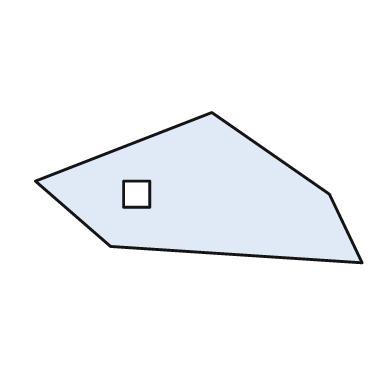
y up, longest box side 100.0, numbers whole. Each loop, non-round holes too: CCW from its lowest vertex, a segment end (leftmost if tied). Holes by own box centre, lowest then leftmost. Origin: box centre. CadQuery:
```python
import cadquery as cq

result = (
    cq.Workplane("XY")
    .moveTo(50.0, -23.0)
    .lineTo(40.0, -2.0)
    .lineTo(4.0, 23.0)
    .lineTo(-50.0, 2.0)
    .lineTo(-27.0, -18.0)
    .close()
    .moveTo(-23.0, -6.0)
    .lineTo(-15.0, -6.0)
    .lineTo(-15.0, 2.0)
    .lineTo(-23.0, 2.0)
    .close()
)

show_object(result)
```